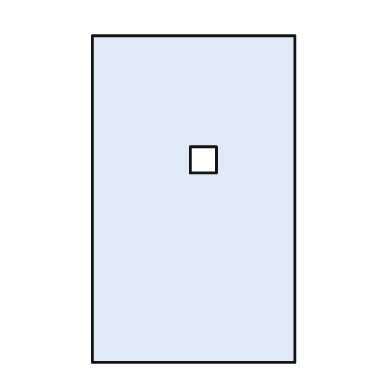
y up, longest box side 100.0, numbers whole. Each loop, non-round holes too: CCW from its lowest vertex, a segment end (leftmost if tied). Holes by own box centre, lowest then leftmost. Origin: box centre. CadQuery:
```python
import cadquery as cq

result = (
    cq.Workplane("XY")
    .moveTo(-31.0, -50.0)
    .lineTo(31.0, -50.0)
    .lineTo(31.0, 50.0)
    .lineTo(-31.0, 50.0)
    .close()
    .moveTo(-1.0, 8.0)
    .lineTo(7.0, 8.0)
    .lineTo(7.0, 16.0)
    .lineTo(-1.0, 16.0)
    .close()
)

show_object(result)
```